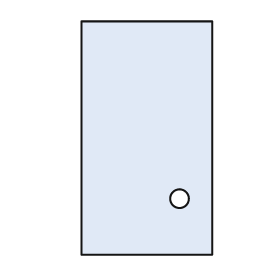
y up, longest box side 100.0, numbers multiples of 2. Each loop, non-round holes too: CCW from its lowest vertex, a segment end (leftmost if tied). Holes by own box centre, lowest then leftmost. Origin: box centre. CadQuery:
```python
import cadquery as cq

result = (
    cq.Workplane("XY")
    .moveTo(-28.0, -50.0)
    .lineTo(28.0, -50.0)
    .lineTo(28.0, 50.0)
    .lineTo(-28.0, 50.0)
    .close()
    .moveTo(14.0, -26.0)
    .circle(4.0)
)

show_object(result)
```